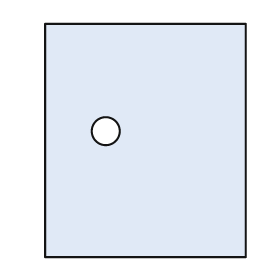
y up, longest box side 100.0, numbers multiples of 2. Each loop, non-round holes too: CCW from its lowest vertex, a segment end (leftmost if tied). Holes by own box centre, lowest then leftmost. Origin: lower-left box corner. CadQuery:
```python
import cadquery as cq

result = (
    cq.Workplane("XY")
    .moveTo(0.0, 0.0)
    .lineTo(86.0, 0.0)
    .lineTo(86.0, 100.0)
    .lineTo(0.0, 100.0)
    .close()
    .moveTo(26.0, 54.0)
    .circle(6.0)
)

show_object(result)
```